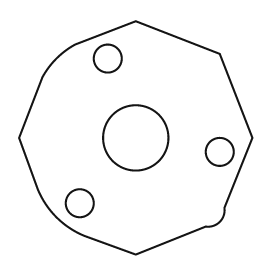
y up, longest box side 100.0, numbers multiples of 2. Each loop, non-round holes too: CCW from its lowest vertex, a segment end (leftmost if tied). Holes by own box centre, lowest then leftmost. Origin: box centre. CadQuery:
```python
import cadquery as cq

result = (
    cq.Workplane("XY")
    .moveTo(0.0, -50.0)
    .lineTo(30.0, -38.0)
    .threePointArc((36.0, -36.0), (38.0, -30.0))
    .lineTo(50.0, 0.0)
    .lineTo(36.0, 36.0)
    .lineTo(0.0, 50.0)
    .lineTo(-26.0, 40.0)
    .threePointArc((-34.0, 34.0), (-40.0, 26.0))
    .lineTo(-50.0, 0.0)
    .lineTo(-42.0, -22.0)
    .threePointArc((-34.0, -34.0), (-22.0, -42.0))
    .close()
    .moveTo(-24.0, -28.0)
    .circle(6.0)
    .moveTo(36.0, -6.0)
    .circle(6.0)
    .moveTo(0.0, 0.0)
    .circle(14.0)
    .moveTo(-12.0, 34.0)
    .circle(6.0)
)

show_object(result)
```